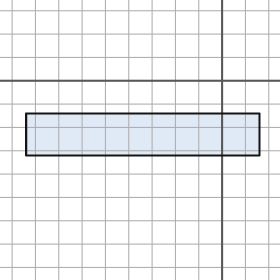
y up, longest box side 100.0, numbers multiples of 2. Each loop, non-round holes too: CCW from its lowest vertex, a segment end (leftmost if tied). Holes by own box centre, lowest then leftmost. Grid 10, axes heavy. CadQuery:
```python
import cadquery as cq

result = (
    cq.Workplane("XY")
    .moveTo(-84.0, -32.0)
    .lineTo(16.0, -32.0)
    .lineTo(16.0, -14.0)
    .lineTo(-84.0, -14.0)
    .close()
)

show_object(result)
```